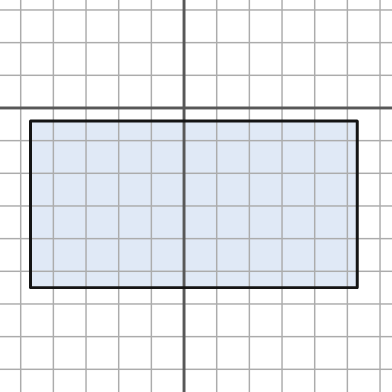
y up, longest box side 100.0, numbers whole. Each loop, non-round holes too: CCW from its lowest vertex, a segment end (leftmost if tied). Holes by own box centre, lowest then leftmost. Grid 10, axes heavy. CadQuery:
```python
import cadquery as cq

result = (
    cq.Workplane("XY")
    .moveTo(-47.0, -55.0)
    .lineTo(53.0, -55.0)
    .lineTo(53.0, -4.0)
    .lineTo(-47.0, -4.0)
    .close()
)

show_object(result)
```